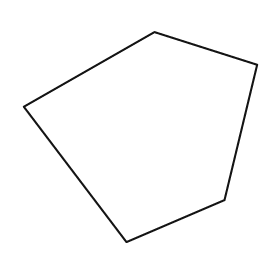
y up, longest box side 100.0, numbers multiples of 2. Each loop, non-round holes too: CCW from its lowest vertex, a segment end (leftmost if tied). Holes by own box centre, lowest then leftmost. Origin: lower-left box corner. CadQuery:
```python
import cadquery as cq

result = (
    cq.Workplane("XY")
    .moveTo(44.0, 0.0)
    .lineTo(86.0, 18.0)
    .lineTo(100.0, 76.0)
    .lineTo(56.0, 90.0)
    .lineTo(0.0, 58.0)
    .close()
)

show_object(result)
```